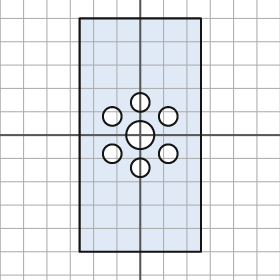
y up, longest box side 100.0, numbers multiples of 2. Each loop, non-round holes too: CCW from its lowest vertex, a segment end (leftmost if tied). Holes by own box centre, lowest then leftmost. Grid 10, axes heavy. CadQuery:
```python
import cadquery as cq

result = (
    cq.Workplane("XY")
    .moveTo(-26.0, -50.0)
    .lineTo(26.0, -50.0)
    .lineTo(26.0, 50.0)
    .lineTo(-26.0, 50.0)
    .close()
    .moveTo(0.0, -14.0)
    .circle(4.0)
    .moveTo(-12.0, -8.0)
    .circle(4.0)
    .moveTo(12.0, -8.0)
    .circle(4.0)
    .moveTo(0.0, 0.0)
    .circle(6.0)
    .moveTo(-12.0, 8.0)
    .circle(4.0)
    .moveTo(12.0, 8.0)
    .circle(4.0)
    .moveTo(0.0, 14.0)
    .circle(4.0)
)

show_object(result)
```